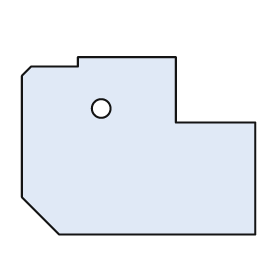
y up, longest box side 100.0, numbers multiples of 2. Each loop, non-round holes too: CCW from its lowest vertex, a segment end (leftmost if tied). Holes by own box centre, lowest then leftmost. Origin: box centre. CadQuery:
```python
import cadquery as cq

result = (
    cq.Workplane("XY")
    .moveTo(-34.0, -38.0)
    .lineTo(50.0, -38.0)
    .lineTo(50.0, 10.0)
    .lineTo(16.0, 10.0)
    .lineTo(16.0, 38.0)
    .lineTo(-26.0, 38.0)
    .lineTo(-26.0, 34.0)
    .lineTo(-46.0, 34.0)
    .lineTo(-50.0, 30.0)
    .lineTo(-50.0, -22.0)
    .close()
    .moveTo(-16.0, 16.0)
    .circle(4.0)
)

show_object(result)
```